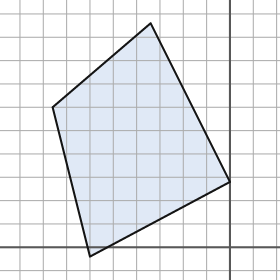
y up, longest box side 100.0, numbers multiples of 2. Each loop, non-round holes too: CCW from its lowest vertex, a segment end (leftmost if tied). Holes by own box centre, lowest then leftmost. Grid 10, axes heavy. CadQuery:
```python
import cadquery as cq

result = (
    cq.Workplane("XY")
    .moveTo(-60.0, -4.0)
    .lineTo(0.0, 28.0)
    .lineTo(-34.0, 96.0)
    .lineTo(-76.0, 60.0)
    .close()
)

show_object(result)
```